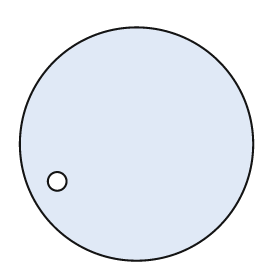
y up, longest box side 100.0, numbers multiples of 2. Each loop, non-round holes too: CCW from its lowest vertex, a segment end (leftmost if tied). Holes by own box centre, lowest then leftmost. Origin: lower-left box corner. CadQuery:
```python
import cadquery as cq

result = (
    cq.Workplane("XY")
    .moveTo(50.0, 50.0)
    .circle(50.0)
    .moveTo(16.0, 34.0)
    .circle(4.0)
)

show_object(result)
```